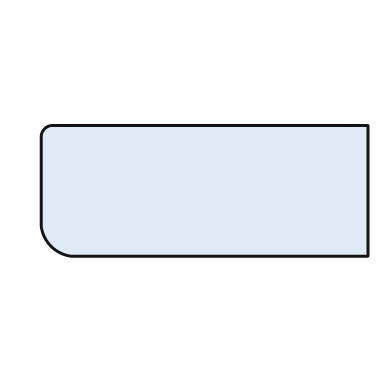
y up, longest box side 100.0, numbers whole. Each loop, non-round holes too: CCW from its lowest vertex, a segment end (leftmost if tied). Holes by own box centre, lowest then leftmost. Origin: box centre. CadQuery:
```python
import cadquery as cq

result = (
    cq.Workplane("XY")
    .moveTo(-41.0, -20.0)
    .lineTo(50.0, -20.0)
    .lineTo(50.0, 20.0)
    .lineTo(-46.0, 20.0)
    .threePointArc((-49.0, 19.0), (-50.0, 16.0))
    .lineTo(-50.0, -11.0)
    .threePointArc((-47.0, -17.0), (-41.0, -20.0))
    .close()
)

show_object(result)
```